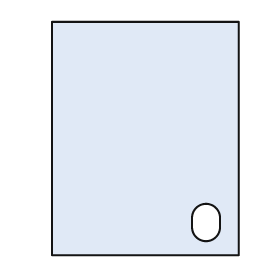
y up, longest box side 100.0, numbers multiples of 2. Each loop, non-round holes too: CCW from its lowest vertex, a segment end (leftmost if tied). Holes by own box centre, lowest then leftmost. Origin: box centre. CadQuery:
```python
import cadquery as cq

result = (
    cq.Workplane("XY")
    .moveTo(-40.0, -50.0)
    .lineTo(40.0, -50.0)
    .lineTo(40.0, 50.0)
    .lineTo(-40.0, 50.0)
    .close()
    .moveTo(20.0, -38.0)
    .threePointArc((26.0, -44.0), (32.0, -38.0))
    .lineTo(32.0, -34.0)
    .threePointArc((26.0, -28.0), (20.0, -34.0))
    .close()
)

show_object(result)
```